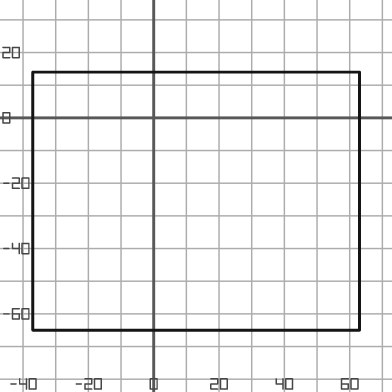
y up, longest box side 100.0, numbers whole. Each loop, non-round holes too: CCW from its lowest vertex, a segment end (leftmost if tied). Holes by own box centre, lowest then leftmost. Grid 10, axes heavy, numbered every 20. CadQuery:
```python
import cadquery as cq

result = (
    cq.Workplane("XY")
    .moveTo(-37.0, -65.0)
    .lineTo(63.0, -65.0)
    .lineTo(63.0, 14.0)
    .lineTo(-37.0, 14.0)
    .close()
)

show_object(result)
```